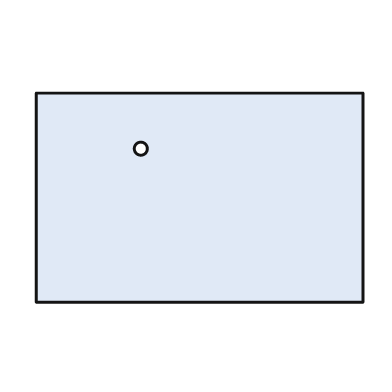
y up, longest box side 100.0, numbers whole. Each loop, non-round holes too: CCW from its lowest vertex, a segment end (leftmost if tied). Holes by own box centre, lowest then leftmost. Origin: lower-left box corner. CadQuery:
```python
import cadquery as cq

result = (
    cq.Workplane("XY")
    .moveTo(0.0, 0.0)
    .lineTo(100.0, 0.0)
    .lineTo(100.0, 64.0)
    .lineTo(0.0, 64.0)
    .close()
    .moveTo(32.0, 47.0)
    .circle(2.0)
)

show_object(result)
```